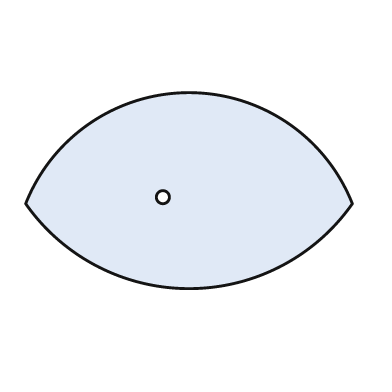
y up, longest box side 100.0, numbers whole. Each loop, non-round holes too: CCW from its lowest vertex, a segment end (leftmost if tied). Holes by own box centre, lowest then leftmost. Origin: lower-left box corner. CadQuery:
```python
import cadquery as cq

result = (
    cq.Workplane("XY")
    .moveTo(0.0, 26.0)
    .threePointArc((50.0, 0.0), (100.0, 26.0))
    .threePointArc((50.0, 60.0), (0.0, 26.0))
    .close()
    .moveTo(42.0, 28.0)
    .circle(2.0)
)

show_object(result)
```